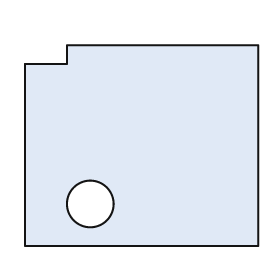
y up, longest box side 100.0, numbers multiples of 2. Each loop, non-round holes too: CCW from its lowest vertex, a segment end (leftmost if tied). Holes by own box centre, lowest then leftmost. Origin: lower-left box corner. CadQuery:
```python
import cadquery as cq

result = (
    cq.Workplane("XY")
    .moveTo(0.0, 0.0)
    .lineTo(100.0, 0.0)
    .lineTo(100.0, 86.0)
    .lineTo(18.0, 86.0)
    .lineTo(18.0, 78.0)
    .lineTo(0.0, 78.0)
    .close()
    .moveTo(28.0, 18.0)
    .circle(10.0)
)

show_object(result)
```